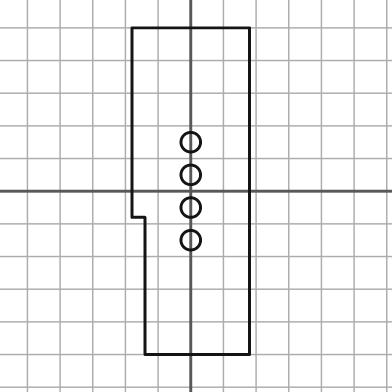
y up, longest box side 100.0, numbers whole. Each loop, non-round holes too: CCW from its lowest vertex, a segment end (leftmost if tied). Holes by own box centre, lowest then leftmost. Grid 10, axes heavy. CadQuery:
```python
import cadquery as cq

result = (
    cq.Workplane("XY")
    .moveTo(-14.0, -50.0)
    .lineTo(18.0, -50.0)
    .lineTo(18.0, 50.0)
    .lineTo(-18.0, 50.0)
    .lineTo(-18.0, -8.0)
    .lineTo(-14.0, -8.0)
    .close()
    .moveTo(0.0, -15.0)
    .circle(3.0)
    .moveTo(0.0, -5.0)
    .circle(3.0)
    .moveTo(0.0, 5.0)
    .circle(3.0)
    .moveTo(0.0, 15.0)
    .circle(3.0)
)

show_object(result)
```